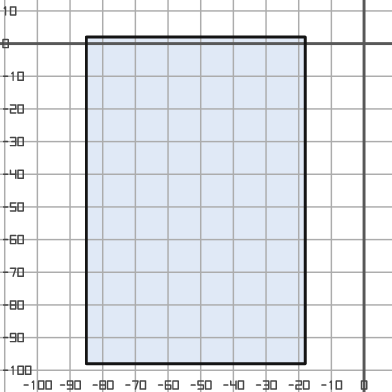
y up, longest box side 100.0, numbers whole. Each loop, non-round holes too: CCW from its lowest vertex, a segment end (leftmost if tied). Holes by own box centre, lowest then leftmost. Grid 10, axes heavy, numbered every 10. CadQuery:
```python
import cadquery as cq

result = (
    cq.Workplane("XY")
    .moveTo(-85.0, -98.0)
    .lineTo(-18.0, -98.0)
    .lineTo(-18.0, 2.0)
    .lineTo(-85.0, 2.0)
    .close()
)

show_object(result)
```